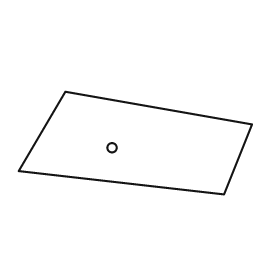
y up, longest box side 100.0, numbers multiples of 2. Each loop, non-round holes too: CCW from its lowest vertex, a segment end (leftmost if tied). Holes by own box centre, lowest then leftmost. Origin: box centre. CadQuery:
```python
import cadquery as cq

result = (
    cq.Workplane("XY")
    .moveTo(38.0, -22.0)
    .lineTo(50.0, 8.0)
    .lineTo(-30.0, 22.0)
    .lineTo(-50.0, -12.0)
    .close()
    .moveTo(-10.0, -2.0)
    .circle(2.0)
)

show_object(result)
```